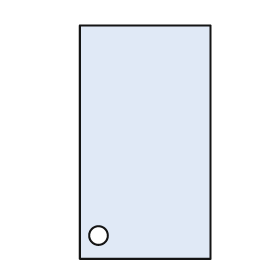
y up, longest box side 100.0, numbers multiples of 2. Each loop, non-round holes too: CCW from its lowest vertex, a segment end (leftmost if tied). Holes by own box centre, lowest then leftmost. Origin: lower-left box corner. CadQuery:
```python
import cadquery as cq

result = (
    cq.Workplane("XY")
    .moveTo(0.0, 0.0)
    .lineTo(56.0, 0.0)
    .lineTo(56.0, 100.0)
    .lineTo(0.0, 100.0)
    .close()
    .moveTo(8.0, 10.0)
    .circle(4.0)
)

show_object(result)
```